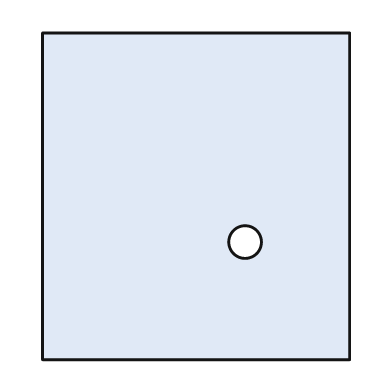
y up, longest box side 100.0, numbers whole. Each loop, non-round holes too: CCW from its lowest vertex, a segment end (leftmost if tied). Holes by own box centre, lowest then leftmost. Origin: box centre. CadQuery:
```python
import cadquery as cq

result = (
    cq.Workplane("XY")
    .moveTo(-47.0, -50.0)
    .lineTo(47.0, -50.0)
    .lineTo(47.0, 50.0)
    .lineTo(-47.0, 50.0)
    .close()
    .moveTo(15.0, -14.0)
    .circle(5.0)
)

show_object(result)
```